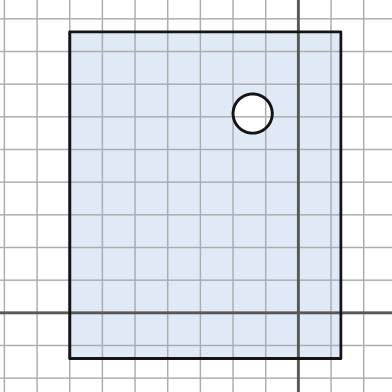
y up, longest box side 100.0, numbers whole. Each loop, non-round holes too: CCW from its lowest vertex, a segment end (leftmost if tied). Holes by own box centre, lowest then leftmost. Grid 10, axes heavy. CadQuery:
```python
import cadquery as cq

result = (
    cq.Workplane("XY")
    .moveTo(-70.0, -14.0)
    .lineTo(13.0, -14.0)
    .lineTo(13.0, 86.0)
    .lineTo(-70.0, 86.0)
    .close()
    .moveTo(-14.0, 61.0)
    .circle(6.0)
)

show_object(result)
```